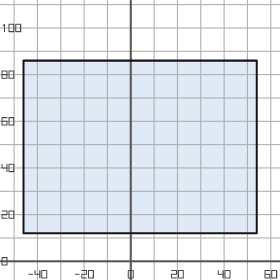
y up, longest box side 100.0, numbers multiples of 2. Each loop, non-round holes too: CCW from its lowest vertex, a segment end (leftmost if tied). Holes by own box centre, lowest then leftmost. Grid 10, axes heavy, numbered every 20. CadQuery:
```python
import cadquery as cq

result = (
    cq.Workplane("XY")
    .moveTo(-46.0, 12.0)
    .lineTo(54.0, 12.0)
    .lineTo(54.0, 86.0)
    .lineTo(-46.0, 86.0)
    .close()
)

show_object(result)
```